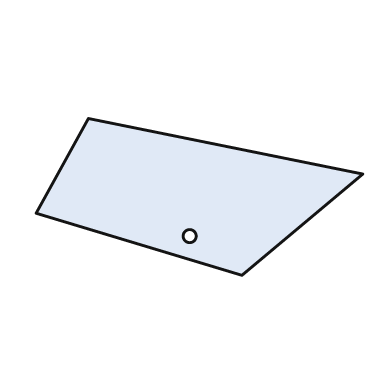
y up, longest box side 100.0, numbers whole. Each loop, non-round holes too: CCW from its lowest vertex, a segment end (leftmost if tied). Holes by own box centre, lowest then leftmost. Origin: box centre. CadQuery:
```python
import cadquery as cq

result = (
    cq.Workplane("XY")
    .moveTo(13.0, -24.0)
    .lineTo(50.0, 7.0)
    .lineTo(-34.0, 24.0)
    .lineTo(-50.0, -5.0)
    .close()
    .moveTo(-3.0, -12.0)
    .circle(2.0)
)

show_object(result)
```